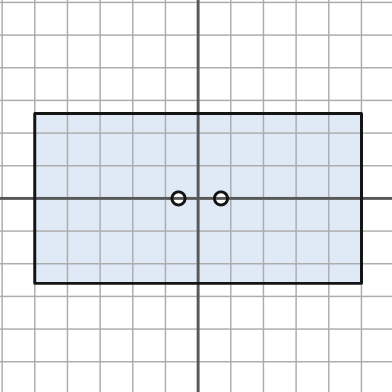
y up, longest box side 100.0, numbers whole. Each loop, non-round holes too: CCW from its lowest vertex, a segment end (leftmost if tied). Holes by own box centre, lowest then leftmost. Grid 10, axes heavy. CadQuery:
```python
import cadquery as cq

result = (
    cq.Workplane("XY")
    .moveTo(-50.0, -26.0)
    .lineTo(50.0, -26.0)
    .lineTo(50.0, 26.0)
    .lineTo(-50.0, 26.0)
    .close()
    .moveTo(-6.0, 0.0)
    .circle(2.0)
    .moveTo(7.0, 0.0)
    .circle(2.0)
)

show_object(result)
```